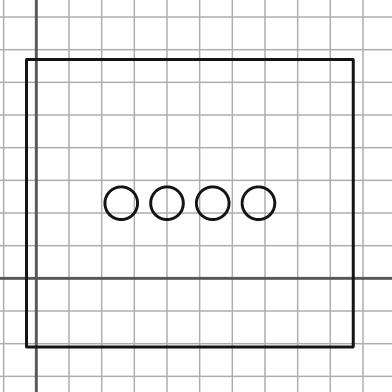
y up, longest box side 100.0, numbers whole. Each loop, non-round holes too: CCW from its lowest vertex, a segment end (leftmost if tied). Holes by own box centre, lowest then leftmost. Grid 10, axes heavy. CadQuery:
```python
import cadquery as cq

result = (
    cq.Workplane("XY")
    .moveTo(-3.0, -21.0)
    .lineTo(97.0, -21.0)
    .lineTo(97.0, 67.0)
    .lineTo(-3.0, 67.0)
    .close()
    .moveTo(26.0, 23.0)
    .circle(5.0)
    .moveTo(40.0, 23.0)
    .circle(5.0)
    .moveTo(54.0, 23.0)
    .circle(5.0)
    .moveTo(68.0, 23.0)
    .circle(5.0)
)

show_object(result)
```